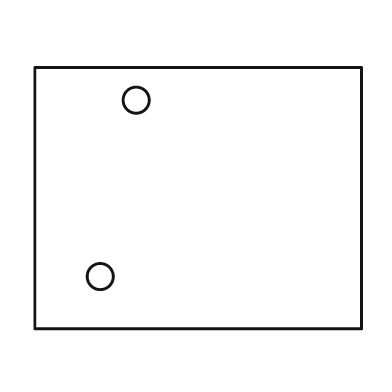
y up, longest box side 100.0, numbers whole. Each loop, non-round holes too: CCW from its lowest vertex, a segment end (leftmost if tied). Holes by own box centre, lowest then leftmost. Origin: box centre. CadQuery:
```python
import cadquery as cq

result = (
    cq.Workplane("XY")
    .moveTo(-50.0, -40.0)
    .lineTo(50.0, -40.0)
    .lineTo(50.0, 40.0)
    .lineTo(-50.0, 40.0)
    .close()
    .moveTo(-30.0, -24.0)
    .circle(4.0)
    .moveTo(-19.0, 30.0)
    .circle(4.0)
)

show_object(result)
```